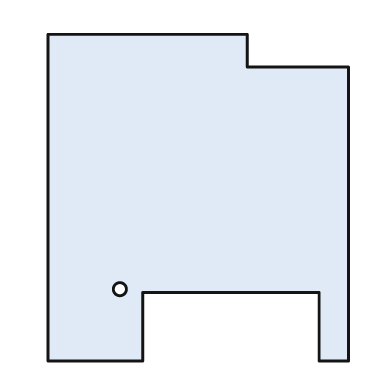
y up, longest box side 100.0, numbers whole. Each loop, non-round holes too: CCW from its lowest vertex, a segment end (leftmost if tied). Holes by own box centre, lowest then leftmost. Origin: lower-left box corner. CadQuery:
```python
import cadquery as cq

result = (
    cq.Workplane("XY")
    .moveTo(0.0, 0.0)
    .lineTo(29.0, 0.0)
    .lineTo(29.0, 21.0)
    .lineTo(83.0, 21.0)
    .lineTo(83.0, 0.0)
    .lineTo(92.0, 0.0)
    .lineTo(92.0, 90.0)
    .lineTo(61.0, 90.0)
    .lineTo(61.0, 100.0)
    .lineTo(0.0, 100.0)
    .close()
    .moveTo(22.0, 22.0)
    .circle(2.0)
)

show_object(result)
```